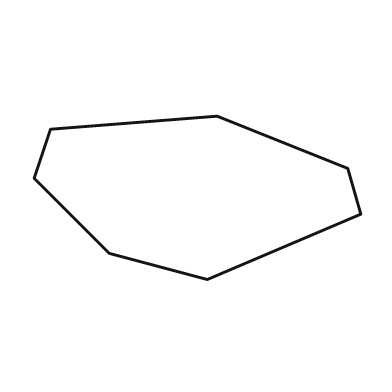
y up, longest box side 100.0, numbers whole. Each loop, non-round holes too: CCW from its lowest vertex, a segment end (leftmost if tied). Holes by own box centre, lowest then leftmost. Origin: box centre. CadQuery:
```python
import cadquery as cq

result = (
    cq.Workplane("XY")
    .moveTo(3.0, -25.0)
    .lineTo(50.0, -5.0)
    .lineTo(46.0, 9.0)
    .lineTo(6.0, 25.0)
    .lineTo(-45.0, 21.0)
    .lineTo(-50.0, 6.0)
    .lineTo(-27.0, -17.0)
    .close()
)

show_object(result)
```